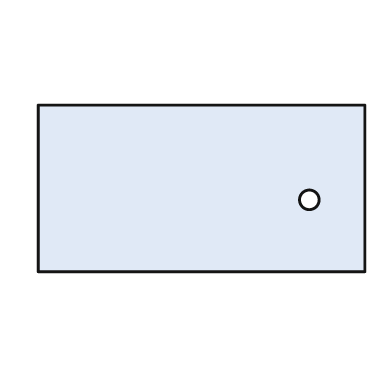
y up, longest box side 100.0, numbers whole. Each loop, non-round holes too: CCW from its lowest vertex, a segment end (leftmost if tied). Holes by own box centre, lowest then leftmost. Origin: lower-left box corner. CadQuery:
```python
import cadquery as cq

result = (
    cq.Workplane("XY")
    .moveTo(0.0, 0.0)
    .lineTo(100.0, 0.0)
    .lineTo(100.0, 51.0)
    .lineTo(0.0, 51.0)
    .close()
    .moveTo(83.0, 22.0)
    .circle(3.0)
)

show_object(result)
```